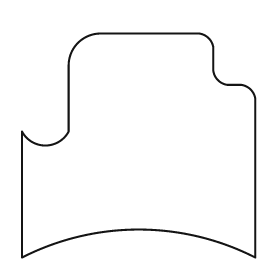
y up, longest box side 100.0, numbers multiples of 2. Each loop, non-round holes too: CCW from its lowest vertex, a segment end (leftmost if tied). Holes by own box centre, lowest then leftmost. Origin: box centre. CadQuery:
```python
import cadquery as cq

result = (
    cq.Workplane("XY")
    .moveTo(-50.0, -48.0)
    .threePointArc((0.0, -36.0), (50.0, -48.0))
    .lineTo(50.0, 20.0)
    .threePointArc((48.0, 24.0), (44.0, 26.0))
    .lineTo(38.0, 26.0)
    .threePointArc((34.0, 28.0), (32.0, 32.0))
    .lineTo(32.0, 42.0)
    .threePointArc((30.0, 46.0), (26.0, 48.0))
    .lineTo(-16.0, 48.0)
    .threePointArc((-26.0, 44.0), (-30.0, 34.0))
    .lineTo(-30.0, 6.0)
    .threePointArc((-40.0, 0.0), (-50.0, 6.0))
    .close()
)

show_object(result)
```